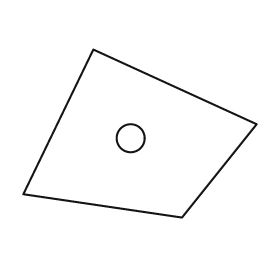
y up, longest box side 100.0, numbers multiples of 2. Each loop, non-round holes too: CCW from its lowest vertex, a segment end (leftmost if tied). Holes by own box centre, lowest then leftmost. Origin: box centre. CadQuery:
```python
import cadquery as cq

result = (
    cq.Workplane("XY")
    .moveTo(18.0, -36.0)
    .lineTo(50.0, 4.0)
    .lineTo(-20.0, 36.0)
    .lineTo(-50.0, -26.0)
    .close()
    .moveTo(-4.0, -2.0)
    .circle(6.0)
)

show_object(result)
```